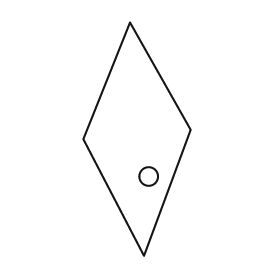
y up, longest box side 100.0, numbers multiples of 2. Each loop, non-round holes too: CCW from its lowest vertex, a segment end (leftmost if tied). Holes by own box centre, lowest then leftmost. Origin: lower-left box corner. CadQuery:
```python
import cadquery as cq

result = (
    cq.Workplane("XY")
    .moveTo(26.0, 0.0)
    .lineTo(46.0, 54.0)
    .lineTo(20.0, 100.0)
    .lineTo(0.0, 50.0)
    .close()
    .moveTo(28.0, 34.0)
    .circle(4.0)
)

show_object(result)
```